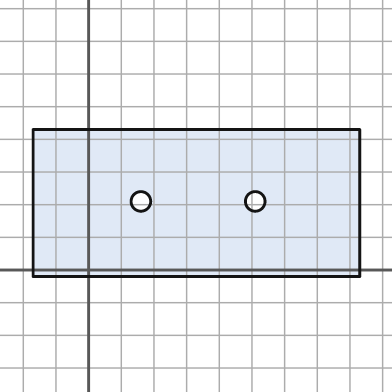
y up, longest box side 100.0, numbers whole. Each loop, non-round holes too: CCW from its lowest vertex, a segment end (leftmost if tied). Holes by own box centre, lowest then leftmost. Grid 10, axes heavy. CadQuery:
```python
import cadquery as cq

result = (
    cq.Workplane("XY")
    .moveTo(-17.0, -2.0)
    .lineTo(83.0, -2.0)
    .lineTo(83.0, 43.0)
    .lineTo(-17.0, 43.0)
    .close()
    .moveTo(16.0, 21.0)
    .circle(3.0)
    .moveTo(51.0, 21.0)
    .circle(3.0)
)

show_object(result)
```